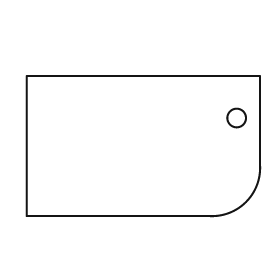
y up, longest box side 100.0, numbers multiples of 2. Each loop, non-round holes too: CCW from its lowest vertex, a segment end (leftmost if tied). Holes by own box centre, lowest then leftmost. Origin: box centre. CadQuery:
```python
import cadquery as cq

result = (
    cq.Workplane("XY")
    .moveTo(-50.0, -30.0)
    .lineTo(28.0, -30.0)
    .threePointArc((44.0, -24.0), (50.0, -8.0))
    .lineTo(50.0, 30.0)
    .lineTo(-50.0, 30.0)
    .close()
    .moveTo(40.0, 12.0)
    .circle(4.0)
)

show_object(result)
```